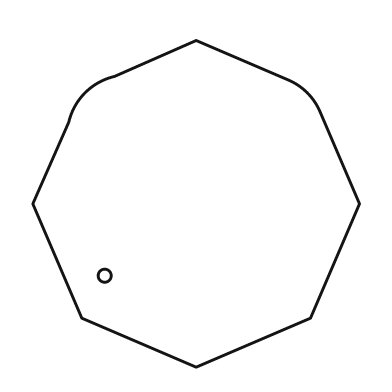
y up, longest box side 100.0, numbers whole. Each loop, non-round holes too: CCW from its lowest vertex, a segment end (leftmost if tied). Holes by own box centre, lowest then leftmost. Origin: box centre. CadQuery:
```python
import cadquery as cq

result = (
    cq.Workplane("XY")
    .moveTo(0.0, -50.0)
    .lineTo(35.0, -35.0)
    .lineTo(50.0, 0.0)
    .lineTo(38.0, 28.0)
    .threePointArc((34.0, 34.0), (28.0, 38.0))
    .lineTo(0.0, 50.0)
    .lineTo(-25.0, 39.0)
    .threePointArc((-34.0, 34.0), (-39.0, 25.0))
    .lineTo(-50.0, 0.0)
    .lineTo(-35.0, -35.0)
    .close()
    .moveTo(-28.0, -22.0)
    .circle(2.0)
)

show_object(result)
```